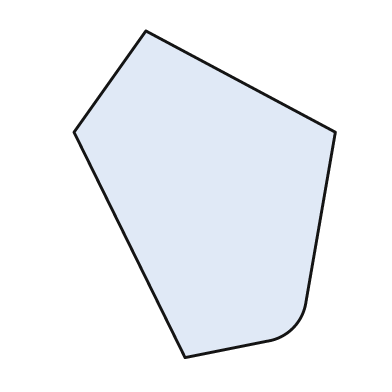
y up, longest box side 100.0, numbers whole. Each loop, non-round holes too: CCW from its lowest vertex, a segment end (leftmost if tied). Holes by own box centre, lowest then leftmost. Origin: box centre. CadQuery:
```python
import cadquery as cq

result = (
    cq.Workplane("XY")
    .moveTo(-6.0, -50.0)
    .lineTo(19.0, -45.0)
    .threePointArc((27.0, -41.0), (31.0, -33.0))
    .lineTo(40.0, 19.0)
    .lineTo(-18.0, 50.0)
    .lineTo(-40.0, 19.0)
    .close()
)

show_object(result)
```